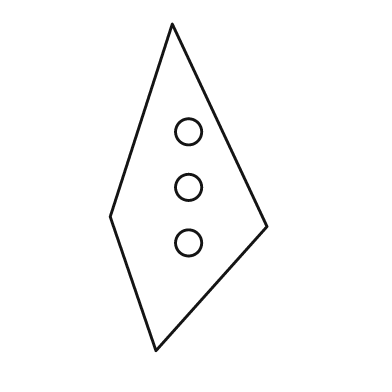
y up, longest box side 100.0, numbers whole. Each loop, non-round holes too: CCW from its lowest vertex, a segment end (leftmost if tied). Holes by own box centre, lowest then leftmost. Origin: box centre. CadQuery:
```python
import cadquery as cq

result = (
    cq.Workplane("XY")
    .moveTo(-10.0, -50.0)
    .lineTo(24.0, -12.0)
    .lineTo(-5.0, 50.0)
    .lineTo(-24.0, -9.0)
    .close()
    .moveTo(0.0, -17.0)
    .circle(4.0)
    .moveTo(0.0, 0.0)
    .circle(4.0)
    .moveTo(0.0, 17.0)
    .circle(4.0)
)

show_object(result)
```